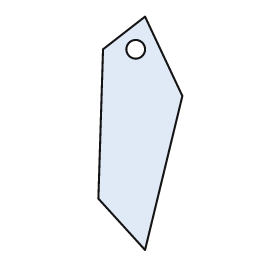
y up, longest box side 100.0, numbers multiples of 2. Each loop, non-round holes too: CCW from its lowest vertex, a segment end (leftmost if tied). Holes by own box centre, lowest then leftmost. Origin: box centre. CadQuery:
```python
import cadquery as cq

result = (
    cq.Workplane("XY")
    .moveTo(2.0, -50.0)
    .lineTo(18.0, 16.0)
    .lineTo(2.0, 50.0)
    .lineTo(-16.0, 36.0)
    .lineTo(-18.0, -28.0)
    .close()
    .moveTo(-2.0, 36.0)
    .circle(4.0)
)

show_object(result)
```